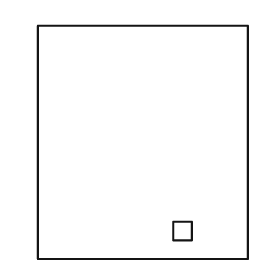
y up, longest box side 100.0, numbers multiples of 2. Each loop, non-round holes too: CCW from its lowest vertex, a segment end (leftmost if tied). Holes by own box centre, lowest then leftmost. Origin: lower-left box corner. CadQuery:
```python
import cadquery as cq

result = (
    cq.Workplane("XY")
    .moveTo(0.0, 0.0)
    .lineTo(90.0, 0.0)
    .lineTo(90.0, 100.0)
    .lineTo(0.0, 100.0)
    .close()
    .moveTo(58.0, 8.0)
    .lineTo(66.0, 8.0)
    .lineTo(66.0, 16.0)
    .lineTo(58.0, 16.0)
    .close()
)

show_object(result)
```